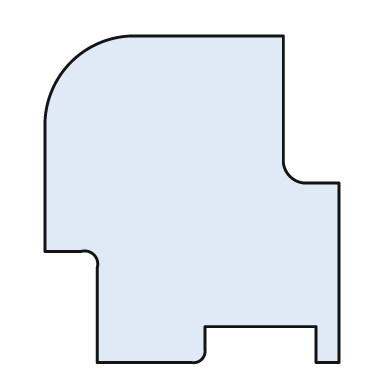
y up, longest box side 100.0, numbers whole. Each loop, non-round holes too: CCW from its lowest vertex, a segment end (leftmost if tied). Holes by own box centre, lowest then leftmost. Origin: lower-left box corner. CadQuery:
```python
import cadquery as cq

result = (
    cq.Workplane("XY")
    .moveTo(16.0, 0.0)
    .lineTo(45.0, 0.0)
    .threePointArc((48.0, 1.0), (49.0, 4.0))
    .lineTo(49.0, 11.0)
    .lineTo(83.0, 11.0)
    .lineTo(83.0, 0.0)
    .lineTo(90.0, 0.0)
    .lineTo(90.0, 55.0)
    .lineTo(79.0, 55.0)
    .threePointArc((75.0, 57.0), (73.0, 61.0))
    .lineTo(73.0, 100.0)
    .lineTo(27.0, 100.0)
    .threePointArc((8.0, 92.0), (0.0, 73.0))
    .lineTo(0.0, 34.0)
    .lineTo(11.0, 34.0)
    .threePointArc((15.0, 33.0), (16.0, 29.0))
    .close()
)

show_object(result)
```